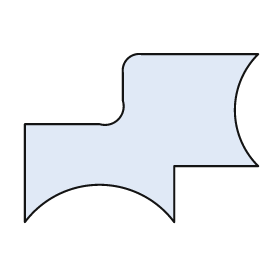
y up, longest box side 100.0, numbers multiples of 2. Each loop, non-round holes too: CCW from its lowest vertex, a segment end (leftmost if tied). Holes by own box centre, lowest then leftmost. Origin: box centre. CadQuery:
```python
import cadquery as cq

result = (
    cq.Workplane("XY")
    .moveTo(-50.0, -36.0)
    .threePointArc((-18.0, -20.0), (14.0, -36.0))
    .lineTo(14.0, -12.0)
    .lineTo(50.0, -12.0)
    .threePointArc((40.0, 12.0), (50.0, 36.0))
    .lineTo(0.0, 36.0)
    .threePointArc((-6.0, 34.0), (-8.0, 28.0))
    .lineTo(-8.0, 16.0)
    .threePointArc((-10.0, 8.0), (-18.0, 6.0))
    .lineTo(-50.0, 6.0)
    .close()
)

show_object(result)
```